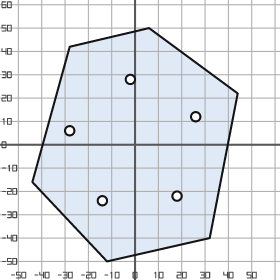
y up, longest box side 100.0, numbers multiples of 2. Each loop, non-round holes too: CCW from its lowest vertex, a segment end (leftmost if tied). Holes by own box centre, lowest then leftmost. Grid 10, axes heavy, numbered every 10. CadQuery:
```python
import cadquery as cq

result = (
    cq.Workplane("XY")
    .moveTo(-12.0, -50.0)
    .lineTo(32.0, -40.0)
    .lineTo(44.0, 22.0)
    .lineTo(6.0, 50.0)
    .lineTo(-28.0, 42.0)
    .lineTo(-44.0, -16.0)
    .close()
    .moveTo(-14.0, -24.0)
    .circle(2.0)
    .moveTo(18.0, -22.0)
    .circle(2.0)
    .moveTo(-28.0, 6.0)
    .circle(2.0)
    .moveTo(26.0, 12.0)
    .circle(2.0)
    .moveTo(-2.0, 28.0)
    .circle(2.0)
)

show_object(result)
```